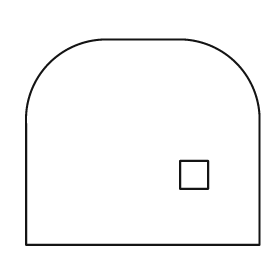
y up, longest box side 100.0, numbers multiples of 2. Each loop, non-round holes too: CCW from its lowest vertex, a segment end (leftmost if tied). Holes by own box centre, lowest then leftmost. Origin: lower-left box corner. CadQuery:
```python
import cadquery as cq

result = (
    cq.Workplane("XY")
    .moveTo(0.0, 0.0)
    .lineTo(100.0, 0.0)
    .lineTo(100.0, 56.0)
    .threePointArc((90.0, 78.0), (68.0, 88.0))
    .lineTo(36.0, 88.0)
    .threePointArc((10.0, 78.0), (0.0, 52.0))
    .close()
    .moveTo(66.0, 24.0)
    .lineTo(78.0, 24.0)
    .lineTo(78.0, 36.0)
    .lineTo(66.0, 36.0)
    .close()
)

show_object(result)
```